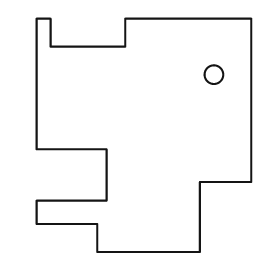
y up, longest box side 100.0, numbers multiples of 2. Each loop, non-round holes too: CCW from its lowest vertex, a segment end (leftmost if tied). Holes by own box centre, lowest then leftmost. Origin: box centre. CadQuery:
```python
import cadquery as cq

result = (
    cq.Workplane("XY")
    .moveTo(-20.0, -50.0)
    .lineTo(24.0, -50.0)
    .lineTo(24.0, -20.0)
    .lineTo(46.0, -20.0)
    .lineTo(46.0, 50.0)
    .lineTo(-8.0, 50.0)
    .lineTo(-8.0, 38.0)
    .lineTo(-40.0, 38.0)
    .lineTo(-40.0, 50.0)
    .lineTo(-46.0, 50.0)
    .lineTo(-46.0, -6.0)
    .lineTo(-16.0, -6.0)
    .lineTo(-16.0, -28.0)
    .lineTo(-46.0, -28.0)
    .lineTo(-46.0, -38.0)
    .lineTo(-20.0, -38.0)
    .close()
    .moveTo(30.0, 26.0)
    .circle(4.0)
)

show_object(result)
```